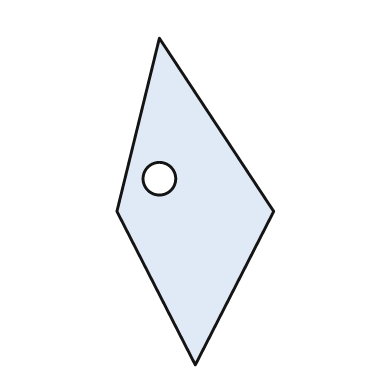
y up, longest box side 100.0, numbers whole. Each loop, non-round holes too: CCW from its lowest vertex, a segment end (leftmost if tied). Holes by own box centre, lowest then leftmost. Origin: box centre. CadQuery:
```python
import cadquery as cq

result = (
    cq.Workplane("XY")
    .moveTo(0.0, -50.0)
    .lineTo(24.0, -3.0)
    .lineTo(-11.0, 50.0)
    .lineTo(-24.0, -3.0)
    .close()
    .moveTo(-11.0, 7.0)
    .circle(5.0)
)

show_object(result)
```